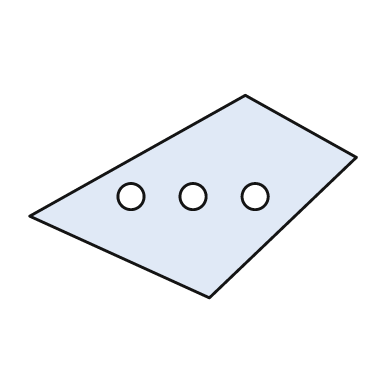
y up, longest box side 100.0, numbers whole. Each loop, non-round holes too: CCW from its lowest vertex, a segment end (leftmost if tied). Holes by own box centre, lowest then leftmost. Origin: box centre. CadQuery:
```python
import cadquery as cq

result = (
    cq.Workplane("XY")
    .moveTo(5.0, -31.0)
    .lineTo(50.0, 12.0)
    .lineTo(16.0, 31.0)
    .lineTo(-50.0, -6.0)
    .close()
    .moveTo(-19.0, 0.0)
    .circle(4.0)
    .moveTo(0.0, 0.0)
    .circle(4.0)
    .moveTo(19.0, 0.0)
    .circle(4.0)
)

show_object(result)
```